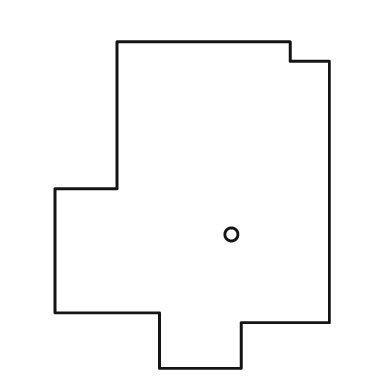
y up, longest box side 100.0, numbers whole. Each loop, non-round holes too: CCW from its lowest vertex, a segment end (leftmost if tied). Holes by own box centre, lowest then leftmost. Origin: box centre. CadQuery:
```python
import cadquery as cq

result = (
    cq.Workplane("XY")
    .moveTo(-10.0, -50.0)
    .lineTo(15.0, -50.0)
    .lineTo(15.0, -36.0)
    .lineTo(42.0, -36.0)
    .lineTo(42.0, 44.0)
    .lineTo(30.0, 44.0)
    .lineTo(30.0, 50.0)
    .lineTo(-23.0, 50.0)
    .lineTo(-23.0, 5.0)
    .lineTo(-42.0, 5.0)
    .lineTo(-42.0, -33.0)
    .lineTo(-10.0, -33.0)
    .close()
    .moveTo(12.0, -9.0)
    .circle(2.0)
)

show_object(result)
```